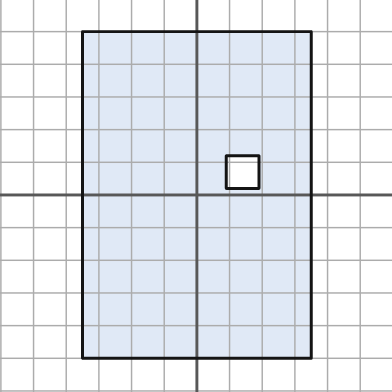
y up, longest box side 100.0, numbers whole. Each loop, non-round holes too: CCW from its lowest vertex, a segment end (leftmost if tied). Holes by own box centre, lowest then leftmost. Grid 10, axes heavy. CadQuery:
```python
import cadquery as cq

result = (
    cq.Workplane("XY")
    .moveTo(-35.0, -50.0)
    .lineTo(35.0, -50.0)
    .lineTo(35.0, 50.0)
    .lineTo(-35.0, 50.0)
    .close()
    .moveTo(9.0, 2.0)
    .lineTo(19.0, 2.0)
    .lineTo(19.0, 12.0)
    .lineTo(9.0, 12.0)
    .close()
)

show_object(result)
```